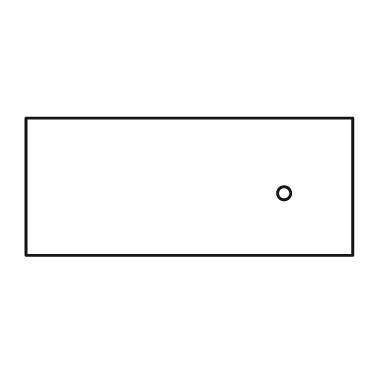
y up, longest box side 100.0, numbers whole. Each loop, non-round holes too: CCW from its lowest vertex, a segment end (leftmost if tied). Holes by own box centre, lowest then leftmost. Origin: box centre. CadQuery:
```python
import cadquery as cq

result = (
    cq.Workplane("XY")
    .moveTo(-50.0, -21.0)
    .lineTo(50.0, -21.0)
    .lineTo(50.0, 21.0)
    .lineTo(-50.0, 21.0)
    .close()
    .moveTo(29.0, -2.0)
    .circle(2.0)
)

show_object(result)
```